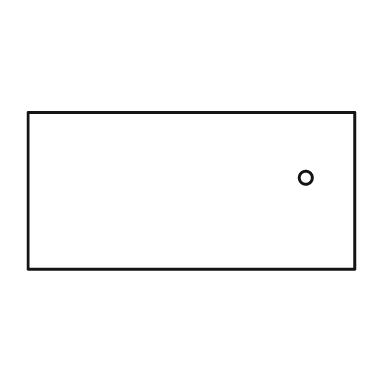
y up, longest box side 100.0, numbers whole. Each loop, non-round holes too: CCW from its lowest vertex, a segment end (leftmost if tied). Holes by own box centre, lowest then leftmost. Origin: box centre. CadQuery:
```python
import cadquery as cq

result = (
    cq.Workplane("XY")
    .moveTo(-50.0, -24.0)
    .lineTo(50.0, -24.0)
    .lineTo(50.0, 24.0)
    .lineTo(-50.0, 24.0)
    .close()
    .moveTo(35.0, 4.0)
    .circle(2.0)
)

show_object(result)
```